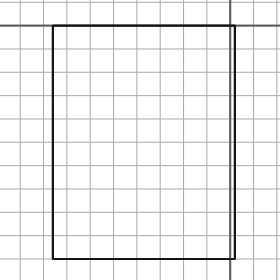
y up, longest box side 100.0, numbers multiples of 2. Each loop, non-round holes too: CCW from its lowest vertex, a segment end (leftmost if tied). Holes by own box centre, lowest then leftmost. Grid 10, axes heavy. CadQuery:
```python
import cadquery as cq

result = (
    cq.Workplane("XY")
    .moveTo(-76.0, -100.0)
    .lineTo(2.0, -100.0)
    .lineTo(2.0, 0.0)
    .lineTo(-76.0, 0.0)
    .close()
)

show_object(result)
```